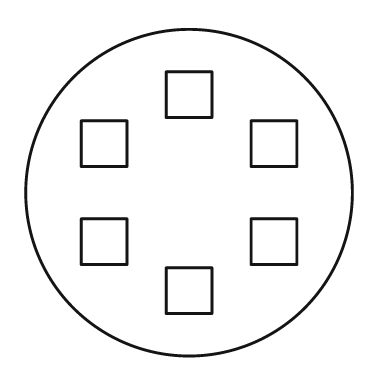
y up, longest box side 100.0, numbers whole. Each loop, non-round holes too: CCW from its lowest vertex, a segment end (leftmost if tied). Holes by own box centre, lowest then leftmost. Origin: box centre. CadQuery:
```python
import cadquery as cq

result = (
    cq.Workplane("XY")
    .moveTo(0.0, 0.0)
    .circle(50.0)
    .moveTo(-7.0, -37.0)
    .lineTo(7.0, -37.0)
    .lineTo(7.0, -23.0)
    .lineTo(-7.0, -23.0)
    .close()
    .moveTo(-33.0, -22.0)
    .lineTo(-19.0, -22.0)
    .lineTo(-19.0, -8.0)
    .lineTo(-33.0, -8.0)
    .close()
    .moveTo(19.0, -22.0)
    .lineTo(33.0, -22.0)
    .lineTo(33.0, -8.0)
    .lineTo(19.0, -8.0)
    .close()
    .moveTo(-33.0, 8.0)
    .lineTo(-19.0, 8.0)
    .lineTo(-19.0, 22.0)
    .lineTo(-33.0, 22.0)
    .close()
    .moveTo(19.0, 8.0)
    .lineTo(33.0, 8.0)
    .lineTo(33.0, 22.0)
    .lineTo(19.0, 22.0)
    .close()
    .moveTo(-7.0, 23.0)
    .lineTo(7.0, 23.0)
    .lineTo(7.0, 37.0)
    .lineTo(-7.0, 37.0)
    .close()
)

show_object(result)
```